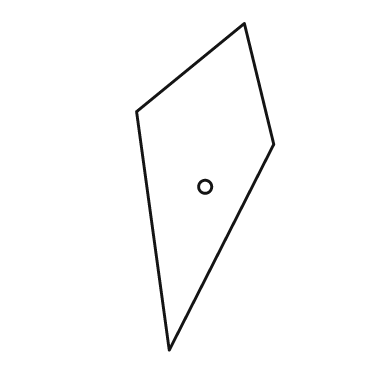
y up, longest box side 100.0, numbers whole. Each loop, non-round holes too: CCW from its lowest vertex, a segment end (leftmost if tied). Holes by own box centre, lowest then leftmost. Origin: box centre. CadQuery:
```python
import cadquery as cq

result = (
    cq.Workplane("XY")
    .moveTo(-11.0, -50.0)
    .lineTo(21.0, 13.0)
    .lineTo(12.0, 50.0)
    .lineTo(-21.0, 23.0)
    .close()
    .moveTo(0.0, 0.0)
    .circle(2.0)
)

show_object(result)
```